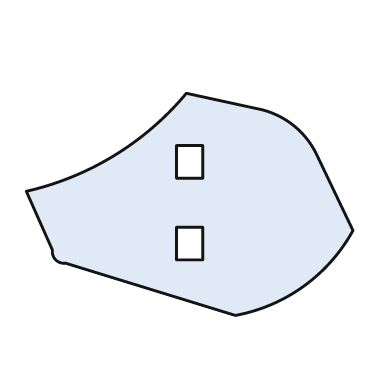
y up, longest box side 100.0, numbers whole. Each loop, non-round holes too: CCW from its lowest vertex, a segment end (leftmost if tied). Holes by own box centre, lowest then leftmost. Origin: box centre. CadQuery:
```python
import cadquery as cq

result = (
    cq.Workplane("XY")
    .moveTo(14.0, -34.0)
    .threePointArc((35.0, -25.0), (50.0, -8.0))
    .lineTo(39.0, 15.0)
    .threePointArc((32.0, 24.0), (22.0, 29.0))
    .lineTo(-1.0, 34.0)
    .threePointArc((-23.0, 15.0), (-50.0, 4.0))
    .lineTo(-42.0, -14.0)
    .threePointArc((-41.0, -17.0), (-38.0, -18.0))
    .close()
    .moveTo(-4.0, -17.0)
    .lineTo(4.0, -17.0)
    .lineTo(4.0, -7.0)
    .lineTo(-4.0, -7.0)
    .close()
    .moveTo(-4.0, 8.0)
    .lineTo(4.0, 8.0)
    .lineTo(4.0, 18.0)
    .lineTo(-4.0, 18.0)
    .close()
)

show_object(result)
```